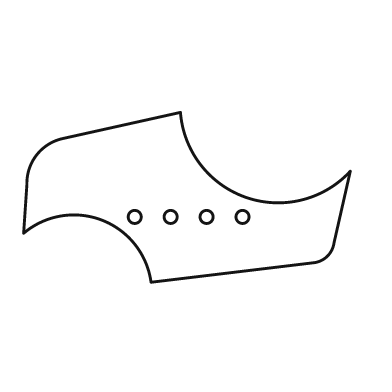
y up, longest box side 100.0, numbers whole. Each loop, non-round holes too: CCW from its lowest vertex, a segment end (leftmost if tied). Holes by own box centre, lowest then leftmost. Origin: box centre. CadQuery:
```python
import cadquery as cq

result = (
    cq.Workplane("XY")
    .moveTo(-11.0, -26.0)
    .lineTo(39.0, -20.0)
    .threePointArc((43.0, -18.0), (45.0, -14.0))
    .lineTo(50.0, 8.0)
    .threePointArc((18.0, 0.0), (-2.0, 26.0))
    .lineTo(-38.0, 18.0)
    .threePointArc((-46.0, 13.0), (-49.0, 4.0))
    .lineTo(-50.0, -11.0)
    .threePointArc((-26.0, -7.0), (-11.0, -26.0))
    .close()
    .moveTo(-16.0, -6.0)
    .circle(2.0)
    .moveTo(-5.0, -6.0)
    .circle(2.0)
    .moveTo(6.0, -6.0)
    .circle(2.0)
    .moveTo(17.0, -6.0)
    .circle(2.0)
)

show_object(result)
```